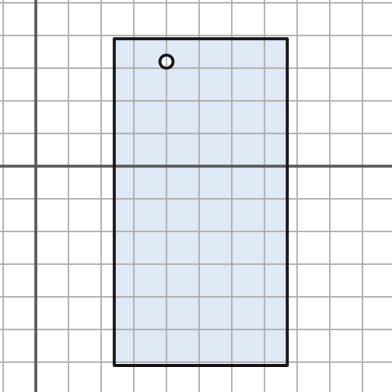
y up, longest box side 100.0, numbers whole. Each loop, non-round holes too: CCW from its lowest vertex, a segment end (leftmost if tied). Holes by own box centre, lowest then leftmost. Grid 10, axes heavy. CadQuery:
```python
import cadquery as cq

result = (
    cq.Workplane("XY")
    .moveTo(24.0, -61.0)
    .lineTo(77.0, -61.0)
    .lineTo(77.0, 39.0)
    .lineTo(24.0, 39.0)
    .close()
    .moveTo(40.0, 32.0)
    .circle(2.0)
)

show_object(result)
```